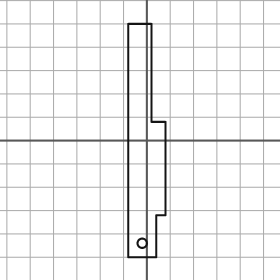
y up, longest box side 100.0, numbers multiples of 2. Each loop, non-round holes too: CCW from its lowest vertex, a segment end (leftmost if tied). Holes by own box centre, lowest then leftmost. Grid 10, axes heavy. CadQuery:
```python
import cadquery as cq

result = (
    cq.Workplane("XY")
    .moveTo(-8.0, -50.0)
    .lineTo(4.0, -50.0)
    .lineTo(4.0, -32.0)
    .lineTo(8.0, -32.0)
    .lineTo(8.0, 8.0)
    .lineTo(2.0, 8.0)
    .lineTo(2.0, 50.0)
    .lineTo(-8.0, 50.0)
    .close()
    .moveTo(-2.0, -44.0)
    .circle(2.0)
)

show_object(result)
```